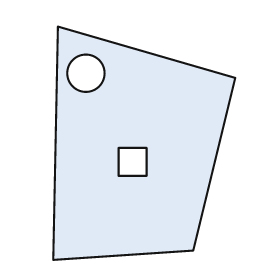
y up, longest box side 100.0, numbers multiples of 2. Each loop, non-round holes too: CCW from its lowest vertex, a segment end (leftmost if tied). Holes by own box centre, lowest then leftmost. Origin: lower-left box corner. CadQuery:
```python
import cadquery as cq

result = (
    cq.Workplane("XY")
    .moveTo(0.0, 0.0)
    .lineTo(60.0, 4.0)
    .lineTo(78.0, 78.0)
    .lineTo(2.0, 100.0)
    .close()
    .moveTo(28.0, 36.0)
    .lineTo(40.0, 36.0)
    .lineTo(40.0, 48.0)
    .lineTo(28.0, 48.0)
    .close()
    .moveTo(14.0, 80.0)
    .circle(8.0)
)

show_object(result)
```